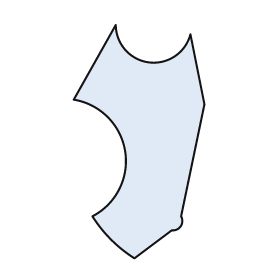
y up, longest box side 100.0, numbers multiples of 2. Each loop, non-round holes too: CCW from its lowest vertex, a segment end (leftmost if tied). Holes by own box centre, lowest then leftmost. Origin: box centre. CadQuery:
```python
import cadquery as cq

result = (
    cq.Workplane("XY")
    .moveTo(-2.0, -50.0)
    .lineTo(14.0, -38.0)
    .threePointArc((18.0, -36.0), (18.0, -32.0))
    .lineTo(28.0, 16.0)
    .lineTo(22.0, 46.0)
    .threePointArc((4.0, 34.0), (-10.0, 50.0))
    .lineTo(-28.0, 18.0)
    .threePointArc((-6.0, -4.0), (-20.0, -32.0))
    .threePointArc((-12.0, -42.0), (-2.0, -50.0))
    .close()
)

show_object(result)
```